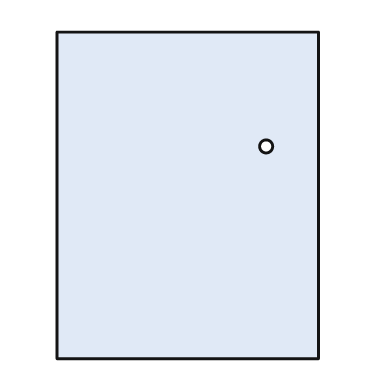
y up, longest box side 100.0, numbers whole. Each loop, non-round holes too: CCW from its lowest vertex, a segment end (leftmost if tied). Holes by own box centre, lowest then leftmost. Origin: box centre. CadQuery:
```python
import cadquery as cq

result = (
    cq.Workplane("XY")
    .moveTo(-40.0, -50.0)
    .lineTo(40.0, -50.0)
    .lineTo(40.0, 50.0)
    .lineTo(-40.0, 50.0)
    .close()
    .moveTo(24.0, 15.0)
    .circle(2.0)
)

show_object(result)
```